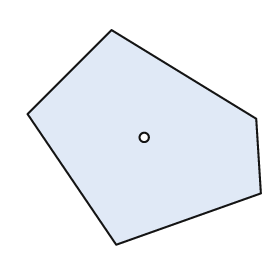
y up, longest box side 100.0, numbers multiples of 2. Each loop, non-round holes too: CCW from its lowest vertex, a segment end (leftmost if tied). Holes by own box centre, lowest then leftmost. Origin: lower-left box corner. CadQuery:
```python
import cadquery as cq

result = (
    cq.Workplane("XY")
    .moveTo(38.0, 0.0)
    .lineTo(100.0, 22.0)
    .lineTo(98.0, 54.0)
    .lineTo(36.0, 92.0)
    .lineTo(0.0, 56.0)
    .close()
    .moveTo(50.0, 46.0)
    .circle(2.0)
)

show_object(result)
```